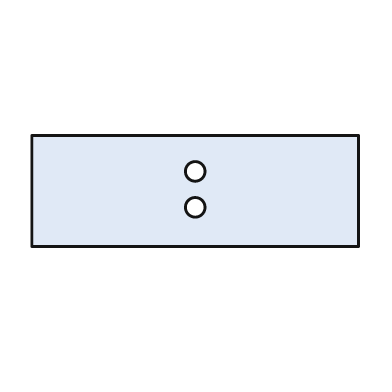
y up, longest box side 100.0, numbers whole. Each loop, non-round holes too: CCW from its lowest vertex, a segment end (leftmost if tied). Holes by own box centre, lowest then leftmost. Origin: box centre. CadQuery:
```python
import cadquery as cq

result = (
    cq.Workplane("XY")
    .moveTo(-50.0, -17.0)
    .lineTo(50.0, -17.0)
    .lineTo(50.0, 17.0)
    .lineTo(-50.0, 17.0)
    .close()
    .moveTo(0.0, -5.0)
    .circle(3.0)
    .moveTo(0.0, 6.0)
    .circle(3.0)
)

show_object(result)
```